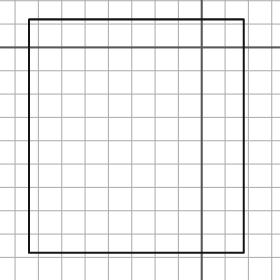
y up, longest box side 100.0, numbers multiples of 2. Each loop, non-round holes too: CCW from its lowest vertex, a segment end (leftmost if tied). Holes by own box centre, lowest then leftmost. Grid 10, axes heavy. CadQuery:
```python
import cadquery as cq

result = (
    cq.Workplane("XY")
    .moveTo(-74.0, -88.0)
    .lineTo(18.0, -88.0)
    .lineTo(18.0, 12.0)
    .lineTo(-74.0, 12.0)
    .close()
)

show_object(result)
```